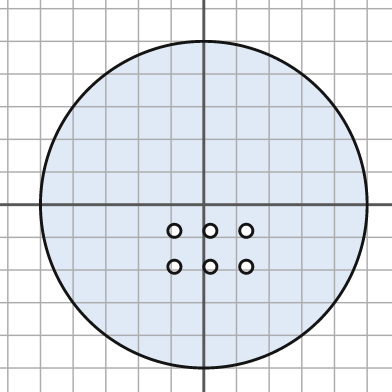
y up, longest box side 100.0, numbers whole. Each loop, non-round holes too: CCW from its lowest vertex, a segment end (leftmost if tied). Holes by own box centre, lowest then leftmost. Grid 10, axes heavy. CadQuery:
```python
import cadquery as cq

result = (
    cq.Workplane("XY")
    .moveTo(0.0, 0.0)
    .circle(50.0)
    .moveTo(-9.0, -19.0)
    .circle(2.0)
    .moveTo(2.0, -19.0)
    .circle(2.0)
    .moveTo(13.0, -19.0)
    .circle(2.0)
    .moveTo(-9.0, -8.0)
    .circle(2.0)
    .moveTo(2.0, -8.0)
    .circle(2.0)
    .moveTo(13.0, -8.0)
    .circle(2.0)
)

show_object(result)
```